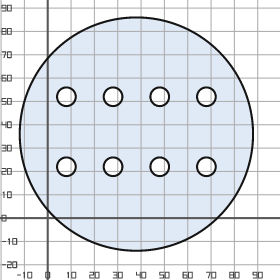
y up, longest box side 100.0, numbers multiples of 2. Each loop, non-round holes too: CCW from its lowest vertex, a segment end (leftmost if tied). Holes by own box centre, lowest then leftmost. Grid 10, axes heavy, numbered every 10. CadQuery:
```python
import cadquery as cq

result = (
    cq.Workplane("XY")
    .moveTo(38.0, 36.0)
    .circle(50.0)
    .moveTo(8.0, 22.0)
    .circle(4.0)
    .moveTo(28.0, 22.0)
    .circle(4.0)
    .moveTo(48.0, 22.0)
    .circle(4.0)
    .moveTo(68.0, 22.0)
    .circle(4.0)
    .moveTo(8.0, 52.0)
    .circle(4.0)
    .moveTo(28.0, 52.0)
    .circle(4.0)
    .moveTo(48.0, 52.0)
    .circle(4.0)
    .moveTo(68.0, 52.0)
    .circle(4.0)
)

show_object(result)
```